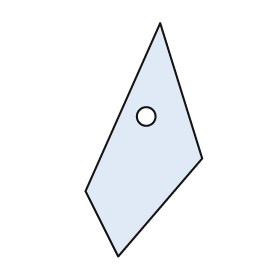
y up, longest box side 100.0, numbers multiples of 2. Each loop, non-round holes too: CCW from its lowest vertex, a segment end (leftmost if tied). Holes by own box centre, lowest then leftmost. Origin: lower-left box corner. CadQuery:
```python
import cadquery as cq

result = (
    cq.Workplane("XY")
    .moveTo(14.0, 0.0)
    .lineTo(50.0, 42.0)
    .lineTo(32.0, 100.0)
    .lineTo(0.0, 28.0)
    .close()
    .moveTo(26.0, 60.0)
    .circle(4.0)
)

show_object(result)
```